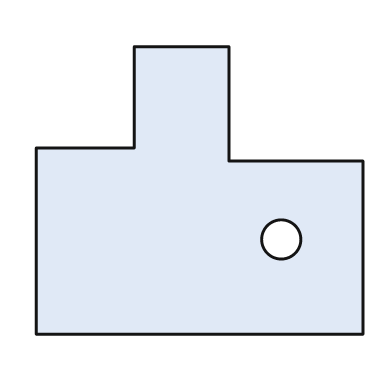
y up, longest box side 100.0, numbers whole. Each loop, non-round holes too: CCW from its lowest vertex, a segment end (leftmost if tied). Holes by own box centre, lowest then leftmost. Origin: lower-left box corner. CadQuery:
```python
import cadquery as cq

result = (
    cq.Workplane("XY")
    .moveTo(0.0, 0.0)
    .lineTo(100.0, 0.0)
    .lineTo(100.0, 53.0)
    .lineTo(59.0, 53.0)
    .lineTo(59.0, 88.0)
    .lineTo(30.0, 88.0)
    .lineTo(30.0, 57.0)
    .lineTo(0.0, 57.0)
    .close()
    .moveTo(75.0, 29.0)
    .circle(6.0)
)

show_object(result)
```